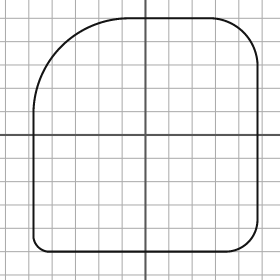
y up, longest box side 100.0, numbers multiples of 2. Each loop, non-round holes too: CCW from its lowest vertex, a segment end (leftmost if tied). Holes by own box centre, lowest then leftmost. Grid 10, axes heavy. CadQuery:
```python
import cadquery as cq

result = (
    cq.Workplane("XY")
    .moveTo(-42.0, -50.0)
    .lineTo(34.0, -50.0)
    .threePointArc((44.0, -46.0), (48.0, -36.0))
    .lineTo(48.0, 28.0)
    .threePointArc((42.0, 44.0), (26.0, 50.0))
    .lineTo(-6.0, 50.0)
    .threePointArc((-36.0, 38.0), (-48.0, 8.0))
    .lineTo(-48.0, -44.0)
    .threePointArc((-46.0, -48.0), (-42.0, -50.0))
    .close()
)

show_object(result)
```